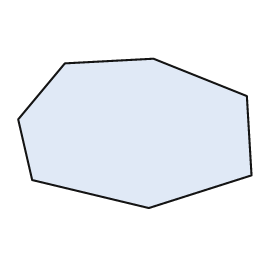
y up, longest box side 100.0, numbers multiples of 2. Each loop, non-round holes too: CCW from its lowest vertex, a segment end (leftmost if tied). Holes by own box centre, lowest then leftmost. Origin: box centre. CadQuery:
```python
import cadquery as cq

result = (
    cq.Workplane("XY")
    .moveTo(6.0, -32.0)
    .lineTo(50.0, -18.0)
    .lineTo(48.0, 16.0)
    .lineTo(8.0, 32.0)
    .lineTo(-30.0, 30.0)
    .lineTo(-50.0, 6.0)
    .lineTo(-44.0, -20.0)
    .close()
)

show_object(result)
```